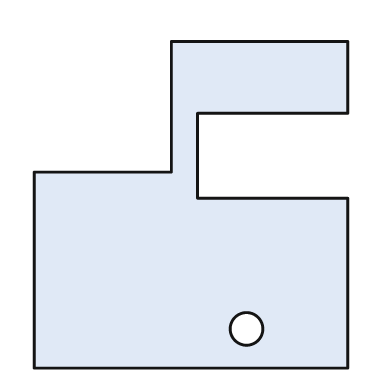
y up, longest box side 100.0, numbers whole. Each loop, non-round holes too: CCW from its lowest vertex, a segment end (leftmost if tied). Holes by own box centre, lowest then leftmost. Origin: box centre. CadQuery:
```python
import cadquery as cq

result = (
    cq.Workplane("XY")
    .moveTo(-48.0, -50.0)
    .lineTo(48.0, -50.0)
    .lineTo(48.0, 2.0)
    .lineTo(2.0, 2.0)
    .lineTo(2.0, 28.0)
    .lineTo(48.0, 28.0)
    .lineTo(48.0, 50.0)
    .lineTo(-6.0, 50.0)
    .lineTo(-6.0, 10.0)
    .lineTo(-48.0, 10.0)
    .close()
    .moveTo(17.0, -38.0)
    .circle(5.0)
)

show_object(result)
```